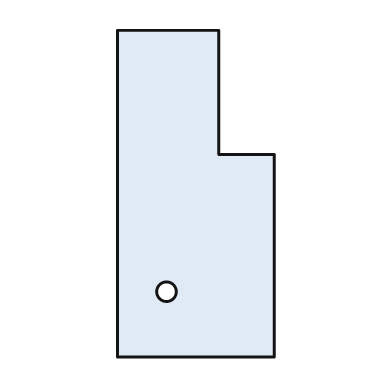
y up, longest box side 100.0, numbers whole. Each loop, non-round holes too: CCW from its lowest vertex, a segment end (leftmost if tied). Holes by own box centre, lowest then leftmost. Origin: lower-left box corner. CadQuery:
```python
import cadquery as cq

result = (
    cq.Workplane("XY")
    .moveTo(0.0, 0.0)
    .lineTo(48.0, 0.0)
    .lineTo(48.0, 62.0)
    .lineTo(31.0, 62.0)
    .lineTo(31.0, 100.0)
    .lineTo(0.0, 100.0)
    .close()
    .moveTo(15.0, 20.0)
    .circle(3.0)
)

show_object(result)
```